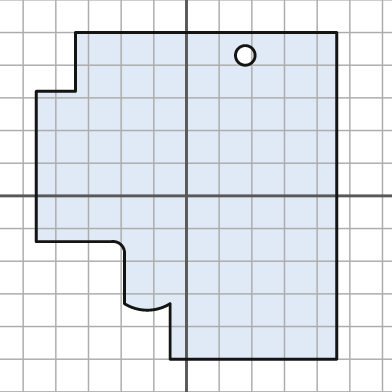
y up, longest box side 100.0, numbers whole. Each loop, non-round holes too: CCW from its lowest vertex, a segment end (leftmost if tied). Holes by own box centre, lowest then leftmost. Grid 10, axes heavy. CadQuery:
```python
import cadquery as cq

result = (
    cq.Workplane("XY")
    .moveTo(-5.0, -50.0)
    .lineTo(46.0, -50.0)
    .lineTo(46.0, 50.0)
    .lineTo(-34.0, 50.0)
    .lineTo(-34.0, 32.0)
    .lineTo(-46.0, 32.0)
    .lineTo(-46.0, -14.0)
    .lineTo(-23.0, -14.0)
    .threePointArc((-20.0, -15.0), (-19.0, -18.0))
    .lineTo(-19.0, -33.0)
    .threePointArc((-12.0, -35.0), (-5.0, -33.0))
    .close()
    .moveTo(18.0, 43.0)
    .circle(3.0)
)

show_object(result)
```